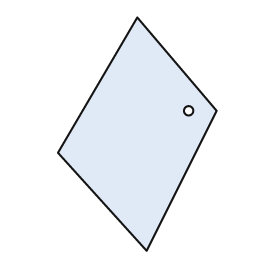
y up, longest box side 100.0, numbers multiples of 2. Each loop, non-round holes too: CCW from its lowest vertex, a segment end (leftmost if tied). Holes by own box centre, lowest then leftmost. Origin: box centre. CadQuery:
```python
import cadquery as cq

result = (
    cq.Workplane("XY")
    .moveTo(4.0, -50.0)
    .lineTo(34.0, 10.0)
    .lineTo(0.0, 50.0)
    .lineTo(-34.0, -8.0)
    .close()
    .moveTo(22.0, 10.0)
    .circle(2.0)
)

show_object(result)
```